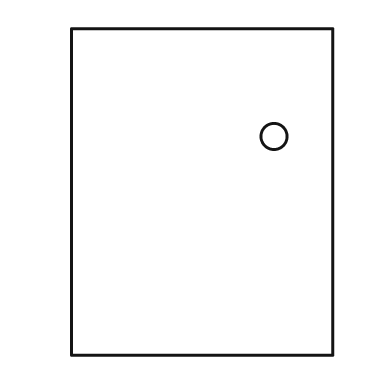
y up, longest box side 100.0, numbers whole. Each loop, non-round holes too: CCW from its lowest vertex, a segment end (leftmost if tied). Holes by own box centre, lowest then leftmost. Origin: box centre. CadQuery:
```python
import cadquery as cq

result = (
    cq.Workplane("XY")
    .moveTo(-40.0, -50.0)
    .lineTo(40.0, -50.0)
    .lineTo(40.0, 50.0)
    .lineTo(-40.0, 50.0)
    .close()
    .moveTo(22.0, 17.0)
    .circle(4.0)
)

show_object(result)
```